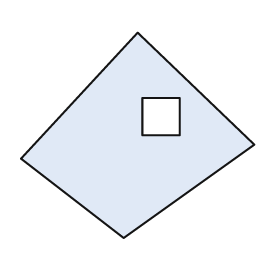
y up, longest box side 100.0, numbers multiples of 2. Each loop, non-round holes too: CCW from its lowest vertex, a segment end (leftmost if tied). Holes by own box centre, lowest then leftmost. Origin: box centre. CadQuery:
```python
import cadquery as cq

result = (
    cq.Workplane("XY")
    .moveTo(-6.0, -44.0)
    .lineTo(50.0, -4.0)
    .lineTo(0.0, 44.0)
    .lineTo(-50.0, -10.0)
    .close()
    .moveTo(2.0, 0.0)
    .lineTo(18.0, 0.0)
    .lineTo(18.0, 16.0)
    .lineTo(2.0, 16.0)
    .close()
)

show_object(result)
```